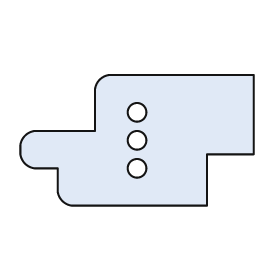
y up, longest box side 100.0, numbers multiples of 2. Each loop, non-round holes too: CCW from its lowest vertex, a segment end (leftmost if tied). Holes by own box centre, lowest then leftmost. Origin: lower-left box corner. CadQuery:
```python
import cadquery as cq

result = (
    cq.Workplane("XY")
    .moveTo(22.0, 0.0)
    .lineTo(80.0, 0.0)
    .lineTo(80.0, 22.0)
    .lineTo(100.0, 22.0)
    .lineTo(100.0, 56.0)
    .lineTo(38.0, 56.0)
    .threePointArc((34.0, 54.0), (32.0, 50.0))
    .lineTo(32.0, 32.0)
    .lineTo(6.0, 32.0)
    .threePointArc((2.0, 30.0), (0.0, 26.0))
    .lineTo(0.0, 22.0)
    .threePointArc((2.0, 18.0), (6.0, 16.0))
    .lineTo(16.0, 16.0)
    .lineTo(16.0, 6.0)
    .threePointArc((18.0, 2.0), (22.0, 0.0))
    .close()
    .moveTo(50.0, 16.0)
    .circle(4.0)
    .moveTo(50.0, 28.0)
    .circle(4.0)
    .moveTo(50.0, 40.0)
    .circle(4.0)
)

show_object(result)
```